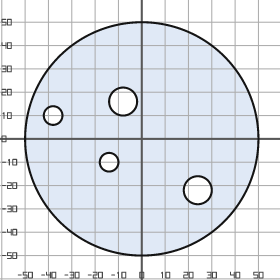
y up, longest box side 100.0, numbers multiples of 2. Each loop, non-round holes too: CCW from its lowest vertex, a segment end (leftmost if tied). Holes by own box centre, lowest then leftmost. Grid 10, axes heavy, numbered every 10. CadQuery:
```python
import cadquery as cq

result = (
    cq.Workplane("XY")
    .moveTo(0.0, 0.0)
    .circle(50.0)
    .moveTo(24.0, -22.0)
    .circle(6.0)
    .moveTo(-14.0, -10.0)
    .circle(4.0)
    .moveTo(-38.0, 10.0)
    .circle(4.0)
    .moveTo(-8.0, 16.0)
    .circle(6.0)
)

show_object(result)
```